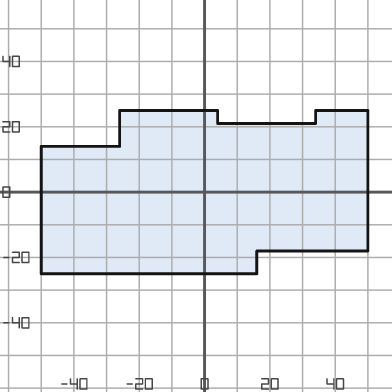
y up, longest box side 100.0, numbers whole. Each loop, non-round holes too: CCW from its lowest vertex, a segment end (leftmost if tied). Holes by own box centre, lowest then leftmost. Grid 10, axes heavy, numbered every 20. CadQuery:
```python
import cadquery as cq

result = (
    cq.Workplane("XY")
    .moveTo(-50.0, -25.0)
    .lineTo(16.0, -25.0)
    .lineTo(16.0, -18.0)
    .lineTo(50.0, -18.0)
    .lineTo(50.0, 25.0)
    .lineTo(34.0, 25.0)
    .lineTo(34.0, 21.0)
    .lineTo(4.0, 21.0)
    .lineTo(4.0, 25.0)
    .lineTo(-26.0, 25.0)
    .lineTo(-26.0, 14.0)
    .lineTo(-50.0, 14.0)
    .close()
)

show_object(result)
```